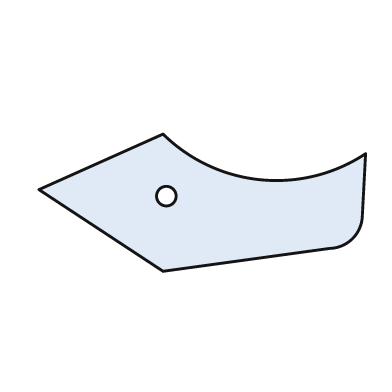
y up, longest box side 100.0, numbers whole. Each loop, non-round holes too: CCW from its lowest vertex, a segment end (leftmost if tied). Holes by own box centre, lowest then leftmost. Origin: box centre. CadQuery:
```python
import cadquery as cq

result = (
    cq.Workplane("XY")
    .moveTo(-12.0, -21.0)
    .lineTo(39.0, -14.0)
    .threePointArc((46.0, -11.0), (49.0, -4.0))
    .lineTo(50.0, 15.0)
    .threePointArc((18.0, 7.0), (-12.0, 21.0))
    .lineTo(-50.0, 4.0)
    .close()
    .moveTo(-11.0, 2.0)
    .circle(3.0)
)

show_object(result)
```